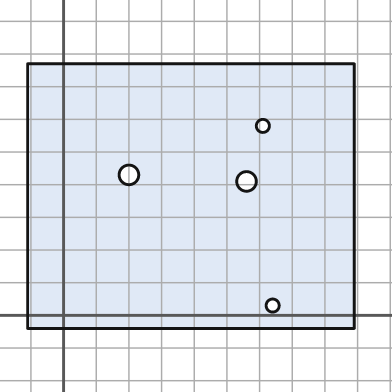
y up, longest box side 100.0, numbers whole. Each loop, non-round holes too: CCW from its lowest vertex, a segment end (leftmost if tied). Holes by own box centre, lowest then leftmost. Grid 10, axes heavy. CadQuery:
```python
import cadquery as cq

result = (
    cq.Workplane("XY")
    .moveTo(-11.0, -4.0)
    .lineTo(89.0, -4.0)
    .lineTo(89.0, 77.0)
    .lineTo(-11.0, 77.0)
    .close()
    .moveTo(64.0, 3.0)
    .circle(2.0)
    .moveTo(56.0, 41.0)
    .circle(3.0)
    .moveTo(20.0, 43.0)
    .circle(3.0)
    .moveTo(61.0, 58.0)
    .circle(2.0)
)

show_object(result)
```